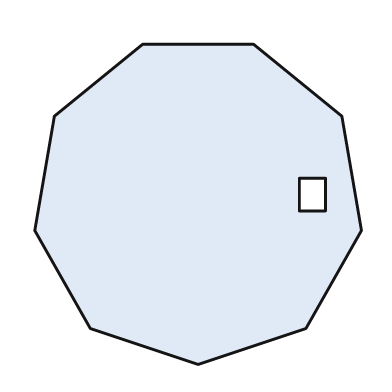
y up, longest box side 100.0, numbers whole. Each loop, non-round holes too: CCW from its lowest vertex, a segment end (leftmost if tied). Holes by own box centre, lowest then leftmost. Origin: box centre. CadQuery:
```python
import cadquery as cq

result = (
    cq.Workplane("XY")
    .moveTo(0.0, -49.0)
    .lineTo(33.0, -38.0)
    .lineTo(50.0, -8.0)
    .lineTo(44.0, 27.0)
    .lineTo(17.0, 49.0)
    .lineTo(-17.0, 49.0)
    .lineTo(-44.0, 27.0)
    .lineTo(-50.0, -8.0)
    .lineTo(-33.0, -38.0)
    .close()
    .moveTo(31.0, -2.0)
    .lineTo(39.0, -2.0)
    .lineTo(39.0, 8.0)
    .lineTo(31.0, 8.0)
    .close()
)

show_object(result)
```